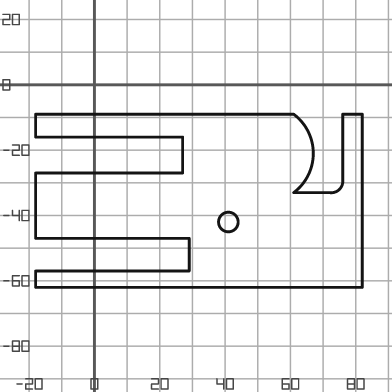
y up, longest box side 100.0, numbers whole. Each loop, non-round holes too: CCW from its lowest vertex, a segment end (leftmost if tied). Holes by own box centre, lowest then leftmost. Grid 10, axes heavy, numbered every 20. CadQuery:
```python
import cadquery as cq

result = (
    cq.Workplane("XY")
    .moveTo(-18.0, -62.0)
    .lineTo(82.0, -62.0)
    .lineTo(82.0, -9.0)
    .lineTo(76.0, -9.0)
    .lineTo(76.0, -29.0)
    .threePointArc((75.0, -32.0), (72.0, -33.0))
    .lineTo(61.0, -33.0)
    .threePointArc((67.0, -21.0), (61.0, -9.0))
    .lineTo(-18.0, -9.0)
    .lineTo(-18.0, -16.0)
    .lineTo(27.0, -16.0)
    .lineTo(27.0, -27.0)
    .lineTo(-18.0, -27.0)
    .lineTo(-18.0, -47.0)
    .lineTo(29.0, -47.0)
    .lineTo(29.0, -57.0)
    .lineTo(-18.0, -57.0)
    .close()
    .moveTo(41.0, -42.0)
    .circle(3.0)
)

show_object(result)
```